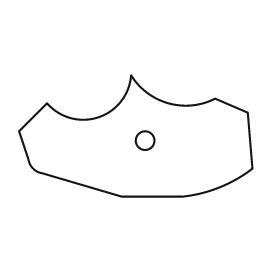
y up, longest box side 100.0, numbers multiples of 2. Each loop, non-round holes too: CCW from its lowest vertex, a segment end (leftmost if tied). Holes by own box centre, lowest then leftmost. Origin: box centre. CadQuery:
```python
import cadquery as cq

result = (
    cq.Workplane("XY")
    .moveTo(-6.0, -26.0)
    .lineTo(20.0, -26.0)
    .threePointArc((36.0, -22.0), (50.0, -14.0))
    .lineTo(48.0, 10.0)
    .lineTo(34.0, 16.0)
    .threePointArc((14.0, 14.0), (-2.0, 26.0))
    .threePointArc((-16.0, 8.0), (-38.0, 14.0))
    .lineTo(-50.0, 2.0)
    .lineTo(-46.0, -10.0)
    .threePointArc((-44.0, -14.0), (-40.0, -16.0))
    .close()
    .moveTo(4.0, -2.0)
    .circle(4.0)
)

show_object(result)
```